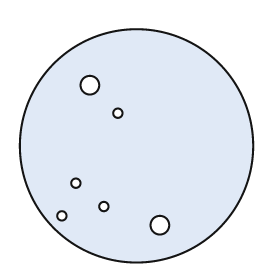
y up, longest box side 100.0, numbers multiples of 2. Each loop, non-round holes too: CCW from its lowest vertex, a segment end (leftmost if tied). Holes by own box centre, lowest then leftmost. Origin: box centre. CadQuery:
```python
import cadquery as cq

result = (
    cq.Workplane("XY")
    .moveTo(0.0, 0.0)
    .circle(50.0)
    .moveTo(10.0, -34.0)
    .circle(4.0)
    .moveTo(-32.0, -30.0)
    .circle(2.0)
    .moveTo(-14.0, -26.0)
    .circle(2.0)
    .moveTo(-26.0, -16.0)
    .circle(2.0)
    .moveTo(-8.0, 14.0)
    .circle(2.0)
    .moveTo(-20.0, 26.0)
    .circle(4.0)
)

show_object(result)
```